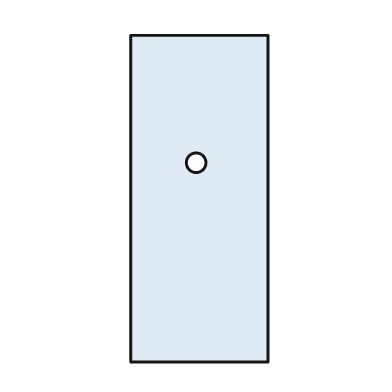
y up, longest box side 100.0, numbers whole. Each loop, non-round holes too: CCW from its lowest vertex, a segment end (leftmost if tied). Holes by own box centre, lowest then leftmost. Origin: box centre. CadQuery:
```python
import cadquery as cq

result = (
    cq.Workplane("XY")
    .moveTo(-21.0, -50.0)
    .lineTo(21.0, -50.0)
    .lineTo(21.0, 50.0)
    .lineTo(-21.0, 50.0)
    .close()
    .moveTo(-1.0, 11.0)
    .circle(3.0)
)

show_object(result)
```